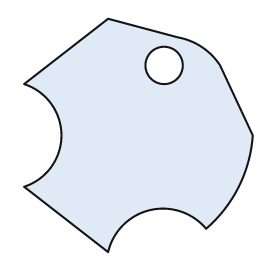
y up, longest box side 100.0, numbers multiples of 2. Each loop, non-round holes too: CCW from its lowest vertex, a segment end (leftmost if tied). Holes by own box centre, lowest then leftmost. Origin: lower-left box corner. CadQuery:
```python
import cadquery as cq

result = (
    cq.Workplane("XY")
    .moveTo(36.0, 0.0)
    .threePointArc((54.0, 18.0), (78.0, 10.0))
    .threePointArc((92.0, 28.0), (98.0, 50.0))
    .lineTo(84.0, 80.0)
    .threePointArc((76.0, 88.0), (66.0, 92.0))
    .lineTo(36.0, 100.0)
    .lineTo(0.0, 72.0)
    .threePointArc((16.0, 50.0), (0.0, 28.0))
    .close()
    .moveTo(60.0, 80.0)
    .circle(8.0)
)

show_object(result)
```